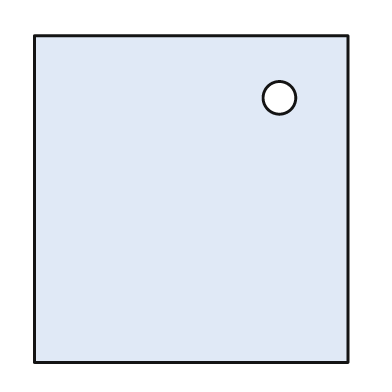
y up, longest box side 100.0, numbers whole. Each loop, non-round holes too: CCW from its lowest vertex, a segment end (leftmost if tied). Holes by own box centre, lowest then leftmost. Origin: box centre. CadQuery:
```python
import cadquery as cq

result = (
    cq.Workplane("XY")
    .moveTo(-48.0, -50.0)
    .lineTo(48.0, -50.0)
    .lineTo(48.0, 50.0)
    .lineTo(-48.0, 50.0)
    .close()
    .moveTo(27.0, 31.0)
    .circle(5.0)
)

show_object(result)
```